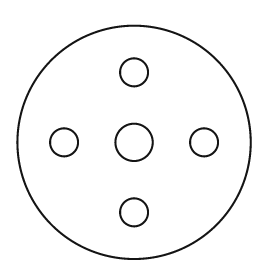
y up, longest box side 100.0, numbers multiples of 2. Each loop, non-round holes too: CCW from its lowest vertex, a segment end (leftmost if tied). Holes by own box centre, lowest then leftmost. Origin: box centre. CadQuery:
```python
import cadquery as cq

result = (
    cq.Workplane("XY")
    .moveTo(0.0, 0.0)
    .circle(50.0)
    .moveTo(0.0, -30.0)
    .circle(6.0)
    .moveTo(-30.0, 0.0)
    .circle(6.0)
    .moveTo(0.0, 0.0)
    .circle(8.0)
    .moveTo(30.0, 0.0)
    .circle(6.0)
    .moveTo(0.0, 30.0)
    .circle(6.0)
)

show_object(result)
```